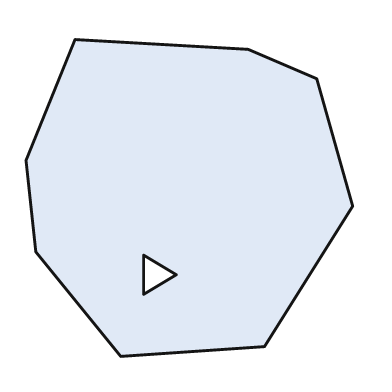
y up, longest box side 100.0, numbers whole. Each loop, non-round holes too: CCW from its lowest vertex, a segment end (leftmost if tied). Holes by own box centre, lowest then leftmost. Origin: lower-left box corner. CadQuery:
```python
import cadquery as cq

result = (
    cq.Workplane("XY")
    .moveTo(29.0, 0.0)
    .lineTo(73.0, 3.0)
    .lineTo(100.0, 46.0)
    .lineTo(89.0, 85.0)
    .lineTo(68.0, 94.0)
    .lineTo(15.0, 97.0)
    .lineTo(0.0, 60.0)
    .lineTo(3.0, 32.0)
    .close()
    .moveTo(36.0, 19.0)
    .lineTo(46.0, 25.0)
    .lineTo(36.0, 31.0)
    .close()
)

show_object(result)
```